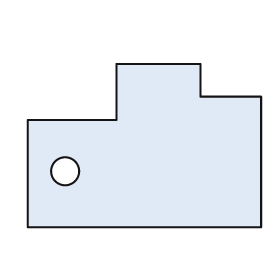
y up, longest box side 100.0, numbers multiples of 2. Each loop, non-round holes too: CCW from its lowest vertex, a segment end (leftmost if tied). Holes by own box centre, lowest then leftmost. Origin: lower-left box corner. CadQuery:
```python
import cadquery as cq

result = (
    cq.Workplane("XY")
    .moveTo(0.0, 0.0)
    .lineTo(100.0, 0.0)
    .lineTo(100.0, 56.0)
    .lineTo(74.0, 56.0)
    .lineTo(74.0, 70.0)
    .lineTo(38.0, 70.0)
    .lineTo(38.0, 46.0)
    .lineTo(0.0, 46.0)
    .close()
    .moveTo(16.0, 24.0)
    .circle(6.0)
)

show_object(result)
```